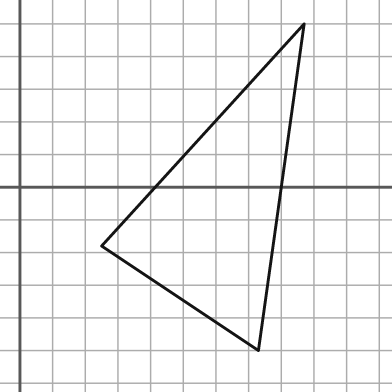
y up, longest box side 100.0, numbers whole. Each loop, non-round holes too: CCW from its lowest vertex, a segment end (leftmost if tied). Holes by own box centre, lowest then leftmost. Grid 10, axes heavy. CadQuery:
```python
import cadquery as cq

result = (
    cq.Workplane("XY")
    .moveTo(73.0, -50.0)
    .lineTo(87.0, 50.0)
    .lineTo(25.0, -18.0)
    .close()
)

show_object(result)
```